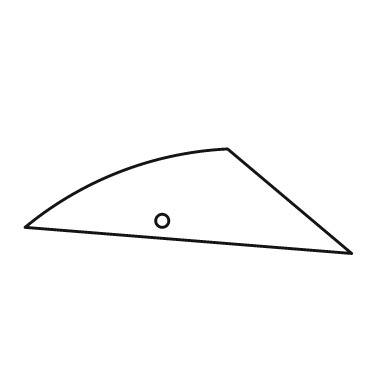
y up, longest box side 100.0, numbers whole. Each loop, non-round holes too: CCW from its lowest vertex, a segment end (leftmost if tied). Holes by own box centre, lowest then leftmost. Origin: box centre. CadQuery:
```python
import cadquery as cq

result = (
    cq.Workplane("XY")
    .moveTo(50.0, -16.0)
    .lineTo(12.0, 16.0)
    .threePointArc((-21.0, 9.0), (-50.0, -8.0))
    .close()
    .moveTo(-8.0, -6.0)
    .circle(2.0)
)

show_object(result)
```